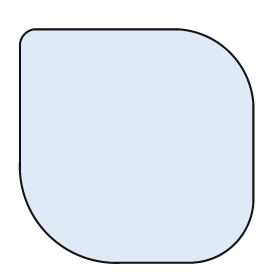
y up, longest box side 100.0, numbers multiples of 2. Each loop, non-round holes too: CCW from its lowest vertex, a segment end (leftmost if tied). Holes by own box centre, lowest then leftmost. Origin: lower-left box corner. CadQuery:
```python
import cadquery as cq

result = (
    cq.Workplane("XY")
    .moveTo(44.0, 0.0)
    .lineTo(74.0, 0.0)
    .threePointArc((92.0, 8.0), (100.0, 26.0))
    .lineTo(100.0, 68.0)
    .threePointArc((90.0, 90.0), (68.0, 100.0))
    .lineTo(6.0, 100.0)
    .threePointArc((2.0, 98.0), (0.0, 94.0))
    .lineTo(0.0, 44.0)
    .threePointArc((12.0, 12.0), (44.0, 0.0))
    .close()
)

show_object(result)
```